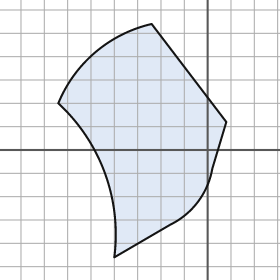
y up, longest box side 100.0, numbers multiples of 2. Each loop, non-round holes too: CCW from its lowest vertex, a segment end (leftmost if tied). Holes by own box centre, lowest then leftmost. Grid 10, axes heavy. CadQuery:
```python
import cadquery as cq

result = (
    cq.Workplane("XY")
    .moveTo(-40.0, -46.0)
    .lineTo(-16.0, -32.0)
    .threePointArc((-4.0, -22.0), (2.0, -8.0))
    .lineTo(8.0, 12.0)
    .lineTo(-24.0, 54.0)
    .threePointArc((-48.0, 42.0), (-64.0, 20.0))
    .threePointArc((-44.0, -10.0), (-40.0, -46.0))
    .close()
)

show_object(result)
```